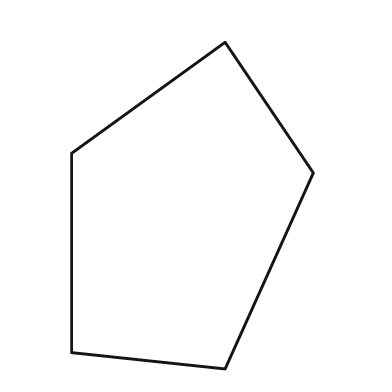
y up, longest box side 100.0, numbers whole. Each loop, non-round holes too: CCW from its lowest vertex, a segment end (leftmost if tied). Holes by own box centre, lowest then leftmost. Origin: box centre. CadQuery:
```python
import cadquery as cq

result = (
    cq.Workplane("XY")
    .moveTo(10.0, -50.0)
    .lineTo(37.0, 10.0)
    .lineTo(10.0, 50.0)
    .lineTo(-37.0, 16.0)
    .lineTo(-37.0, -45.0)
    .close()
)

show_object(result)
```